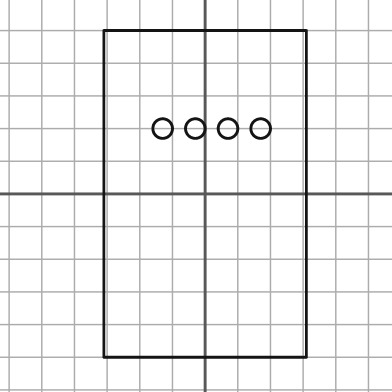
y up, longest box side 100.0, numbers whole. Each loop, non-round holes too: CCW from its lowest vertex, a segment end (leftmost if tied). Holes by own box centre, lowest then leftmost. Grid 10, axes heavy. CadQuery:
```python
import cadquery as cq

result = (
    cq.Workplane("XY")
    .moveTo(-31.0, -50.0)
    .lineTo(31.0, -50.0)
    .lineTo(31.0, 50.0)
    .lineTo(-31.0, 50.0)
    .close()
    .moveTo(-13.0, 20.0)
    .circle(3.0)
    .moveTo(-3.0, 20.0)
    .circle(3.0)
    .moveTo(7.0, 20.0)
    .circle(3.0)
    .moveTo(17.0, 20.0)
    .circle(3.0)
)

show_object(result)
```